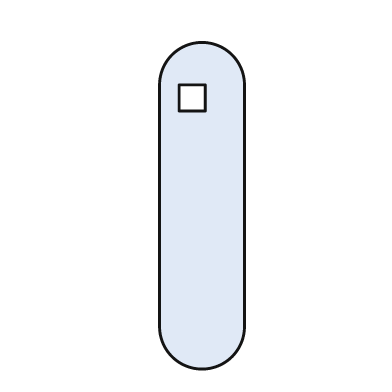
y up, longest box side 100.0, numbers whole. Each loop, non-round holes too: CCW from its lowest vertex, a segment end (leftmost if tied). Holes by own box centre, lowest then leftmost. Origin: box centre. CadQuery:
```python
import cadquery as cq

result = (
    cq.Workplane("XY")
    .moveTo(-13.0, -37.0)
    .threePointArc((0.0, -50.0), (13.0, -37.0))
    .lineTo(13.0, 37.0)
    .threePointArc((0.0, 50.0), (-13.0, 37.0))
    .close()
    .moveTo(-7.0, 29.0)
    .lineTo(1.0, 29.0)
    .lineTo(1.0, 37.0)
    .lineTo(-7.0, 37.0)
    .close()
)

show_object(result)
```